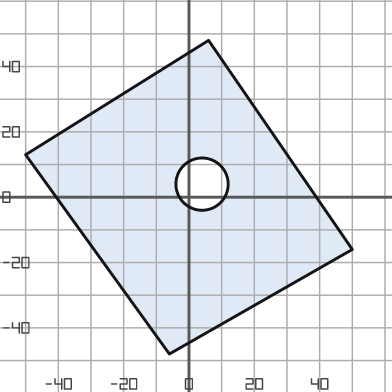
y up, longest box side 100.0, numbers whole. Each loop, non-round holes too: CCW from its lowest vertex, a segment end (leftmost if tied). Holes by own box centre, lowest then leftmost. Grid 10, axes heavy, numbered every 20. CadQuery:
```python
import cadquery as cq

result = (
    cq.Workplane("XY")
    .moveTo(-6.0, -48.0)
    .lineTo(50.0, -16.0)
    .lineTo(6.0, 48.0)
    .lineTo(-50.0, 13.0)
    .close()
    .moveTo(4.0, 4.0)
    .circle(8.0)
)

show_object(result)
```